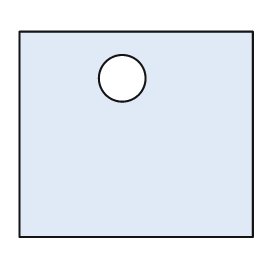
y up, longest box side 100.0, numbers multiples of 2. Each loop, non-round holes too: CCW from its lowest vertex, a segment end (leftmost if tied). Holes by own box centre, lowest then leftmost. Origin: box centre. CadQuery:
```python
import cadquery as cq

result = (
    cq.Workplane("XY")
    .moveTo(-50.0, -44.0)
    .lineTo(50.0, -44.0)
    .lineTo(50.0, 44.0)
    .lineTo(-50.0, 44.0)
    .close()
    .moveTo(-6.0, 24.0)
    .circle(10.0)
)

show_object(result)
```